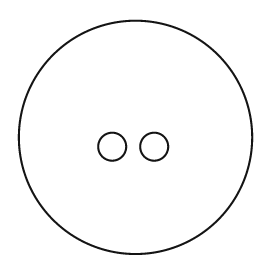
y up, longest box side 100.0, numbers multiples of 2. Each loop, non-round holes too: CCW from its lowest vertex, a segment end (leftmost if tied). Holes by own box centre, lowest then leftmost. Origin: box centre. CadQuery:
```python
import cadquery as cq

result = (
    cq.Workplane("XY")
    .moveTo(0.0, 0.0)
    .circle(50.0)
    .moveTo(-10.0, -4.0)
    .circle(6.0)
    .moveTo(8.0, -4.0)
    .circle(6.0)
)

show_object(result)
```